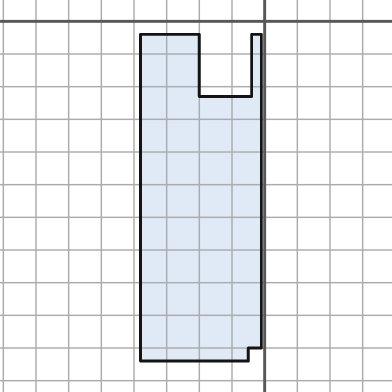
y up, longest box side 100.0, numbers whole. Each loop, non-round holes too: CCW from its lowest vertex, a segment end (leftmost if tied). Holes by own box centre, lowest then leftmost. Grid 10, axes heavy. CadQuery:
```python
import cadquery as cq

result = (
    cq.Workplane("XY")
    .moveTo(-38.0, -104.0)
    .lineTo(-5.0, -104.0)
    .lineTo(-5.0, -100.0)
    .lineTo(-1.0, -100.0)
    .lineTo(-1.0, -4.0)
    .lineTo(-4.0, -4.0)
    .lineTo(-4.0, -23.0)
    .lineTo(-20.0, -23.0)
    .lineTo(-20.0, -4.0)
    .lineTo(-38.0, -4.0)
    .close()
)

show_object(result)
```